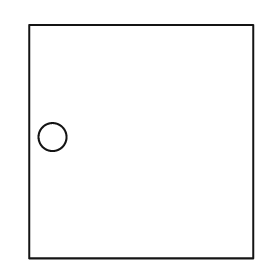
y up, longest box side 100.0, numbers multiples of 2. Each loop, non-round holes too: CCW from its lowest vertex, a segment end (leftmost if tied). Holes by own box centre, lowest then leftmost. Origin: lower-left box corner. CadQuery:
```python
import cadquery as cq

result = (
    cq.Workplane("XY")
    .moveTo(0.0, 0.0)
    .lineTo(96.0, 0.0)
    .lineTo(96.0, 100.0)
    .lineTo(0.0, 100.0)
    .close()
    .moveTo(10.0, 52.0)
    .circle(6.0)
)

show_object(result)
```